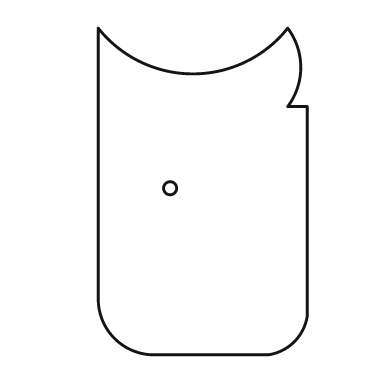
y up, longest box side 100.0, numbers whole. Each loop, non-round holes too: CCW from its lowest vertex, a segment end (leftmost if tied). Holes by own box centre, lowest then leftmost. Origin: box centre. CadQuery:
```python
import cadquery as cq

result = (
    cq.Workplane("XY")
    .moveTo(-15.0, -50.0)
    .lineTo(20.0, -50.0)
    .threePointArc((28.0, -46.0), (32.0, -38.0))
    .lineTo(32.0, 26.0)
    .lineTo(26.0, 26.0)
    .threePointArc((30.0, 38.0), (26.0, 50.0))
    .threePointArc((-3.0, 36.0), (-32.0, 50.0))
    .lineTo(-32.0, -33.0)
    .threePointArc((-27.0, -45.0), (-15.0, -50.0))
    .close()
    .moveTo(-10.0, 1.0)
    .circle(2.0)
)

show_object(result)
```